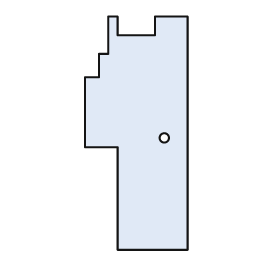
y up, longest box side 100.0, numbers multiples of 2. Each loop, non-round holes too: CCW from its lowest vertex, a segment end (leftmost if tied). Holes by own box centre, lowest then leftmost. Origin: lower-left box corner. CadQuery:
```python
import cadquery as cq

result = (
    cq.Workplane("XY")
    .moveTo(14.0, 0.0)
    .lineTo(44.0, 0.0)
    .lineTo(44.0, 100.0)
    .lineTo(30.0, 100.0)
    .lineTo(30.0, 92.0)
    .lineTo(14.0, 92.0)
    .lineTo(14.0, 100.0)
    .lineTo(10.0, 100.0)
    .lineTo(10.0, 84.0)
    .lineTo(6.0, 84.0)
    .lineTo(6.0, 74.0)
    .lineTo(0.0, 74.0)
    .lineTo(0.0, 44.0)
    .lineTo(14.0, 44.0)
    .close()
    .moveTo(34.0, 48.0)
    .circle(2.0)
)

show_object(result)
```